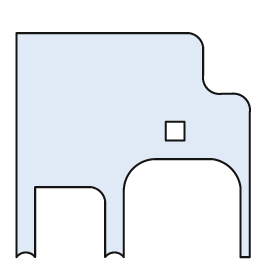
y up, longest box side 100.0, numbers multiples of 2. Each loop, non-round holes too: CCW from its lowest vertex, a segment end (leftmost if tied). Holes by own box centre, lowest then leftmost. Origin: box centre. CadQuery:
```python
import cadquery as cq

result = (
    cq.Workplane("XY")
    .moveTo(-50.0, -48.0)
    .threePointArc((-46.0, -46.0), (-42.0, -48.0))
    .lineTo(-42.0, -18.0)
    .lineTo(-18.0, -18.0)
    .threePointArc((-14.0, -20.0), (-12.0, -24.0))
    .lineTo(-12.0, -48.0)
    .threePointArc((-8.0, -46.0), (-4.0, -48.0))
    .lineTo(-4.0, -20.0)
    .threePointArc((0.0, -10.0), (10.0, -6.0))
    .lineTo(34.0, -6.0)
    .threePointArc((42.0, -10.0), (46.0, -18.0))
    .lineTo(46.0, -48.0)
    .lineTo(50.0, -48.0)
    .lineTo(50.0, 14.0)
    .threePointArc((48.0, 20.0), (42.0, 22.0))
    .lineTo(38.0, 22.0)
    .threePointArc((32.0, 24.0), (30.0, 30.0))
    .lineTo(30.0, 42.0)
    .threePointArc((28.0, 46.0), (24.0, 48.0))
    .lineTo(-50.0, 48.0)
    .close()
    .moveTo(14.0, 2.0)
    .lineTo(22.0, 2.0)
    .lineTo(22.0, 10.0)
    .lineTo(14.0, 10.0)
    .close()
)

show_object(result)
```